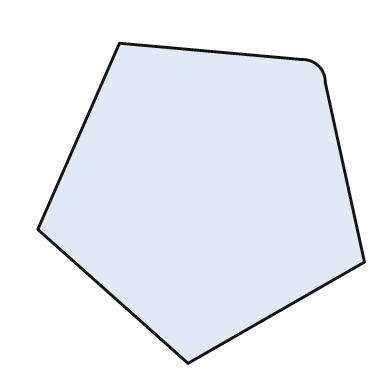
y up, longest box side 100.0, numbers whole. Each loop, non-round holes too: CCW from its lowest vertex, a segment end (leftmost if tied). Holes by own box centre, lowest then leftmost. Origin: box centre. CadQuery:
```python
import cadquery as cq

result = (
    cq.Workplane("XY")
    .moveTo(-4.0, -49.0)
    .lineTo(50.0, -18.0)
    .lineTo(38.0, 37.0)
    .threePointArc((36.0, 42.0), (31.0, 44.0))
    .lineTo(-25.0, 49.0)
    .lineTo(-50.0, -8.0)
    .close()
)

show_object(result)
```